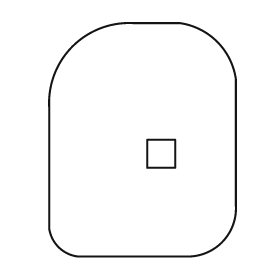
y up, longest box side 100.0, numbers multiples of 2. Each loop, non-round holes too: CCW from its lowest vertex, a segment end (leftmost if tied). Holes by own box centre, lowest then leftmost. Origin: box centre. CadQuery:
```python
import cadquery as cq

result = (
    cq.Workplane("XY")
    .moveTo(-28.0, -50.0)
    .lineTo(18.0, -50.0)
    .threePointArc((34.0, -44.0), (40.0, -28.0))
    .lineTo(40.0, 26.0)
    .threePointArc((32.0, 42.0), (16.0, 50.0))
    .lineTo(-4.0, 50.0)
    .threePointArc((-30.0, 40.0), (-40.0, 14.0))
    .lineTo(-40.0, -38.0)
    .threePointArc((-36.0, -46.0), (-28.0, -50.0))
    .close()
    .moveTo(2.0, -12.0)
    .lineTo(14.0, -12.0)
    .lineTo(14.0, 0.0)
    .lineTo(2.0, 0.0)
    .close()
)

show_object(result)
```